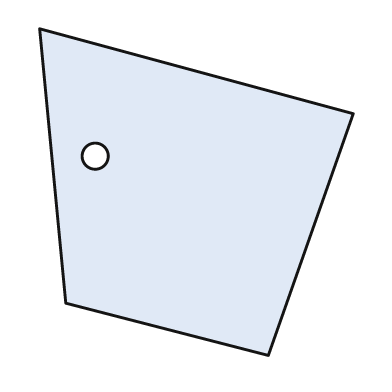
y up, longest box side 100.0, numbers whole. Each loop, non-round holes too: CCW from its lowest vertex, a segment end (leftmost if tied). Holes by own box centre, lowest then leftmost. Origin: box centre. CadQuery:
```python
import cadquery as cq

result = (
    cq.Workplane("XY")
    .moveTo(22.0, -50.0)
    .lineTo(48.0, 24.0)
    .lineTo(-48.0, 50.0)
    .lineTo(-40.0, -34.0)
    .close()
    .moveTo(-31.0, 11.0)
    .circle(4.0)
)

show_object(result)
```